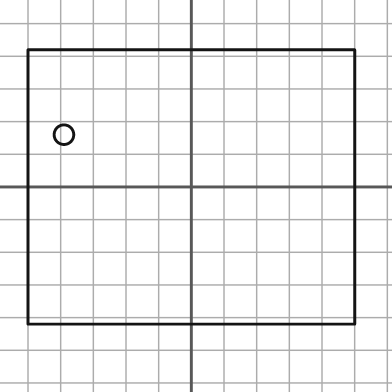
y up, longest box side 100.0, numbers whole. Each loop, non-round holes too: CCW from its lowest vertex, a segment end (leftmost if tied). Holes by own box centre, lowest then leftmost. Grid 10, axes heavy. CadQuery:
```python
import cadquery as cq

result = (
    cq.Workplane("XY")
    .moveTo(-50.0, -42.0)
    .lineTo(50.0, -42.0)
    .lineTo(50.0, 42.0)
    .lineTo(-50.0, 42.0)
    .close()
    .moveTo(-39.0, 16.0)
    .circle(3.0)
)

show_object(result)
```